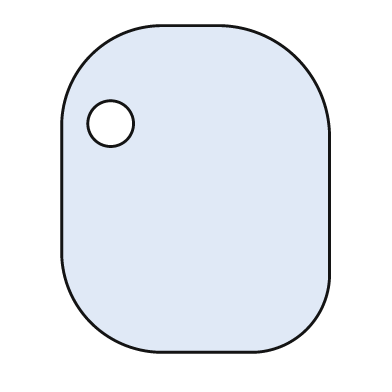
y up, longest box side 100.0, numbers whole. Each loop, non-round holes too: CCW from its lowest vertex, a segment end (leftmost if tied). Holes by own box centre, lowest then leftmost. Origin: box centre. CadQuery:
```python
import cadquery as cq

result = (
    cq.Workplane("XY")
    .moveTo(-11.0, -50.0)
    .lineTo(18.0, -50.0)
    .threePointArc((34.0, -43.0), (41.0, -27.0))
    .lineTo(41.0, 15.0)
    .threePointArc((31.0, 40.0), (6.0, 50.0))
    .lineTo(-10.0, 50.0)
    .threePointArc((-32.0, 41.0), (-41.0, 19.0))
    .lineTo(-41.0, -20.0)
    .threePointArc((-32.0, -41.0), (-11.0, -50.0))
    .close()
    .moveTo(-26.0, 20.0)
    .circle(7.0)
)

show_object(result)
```